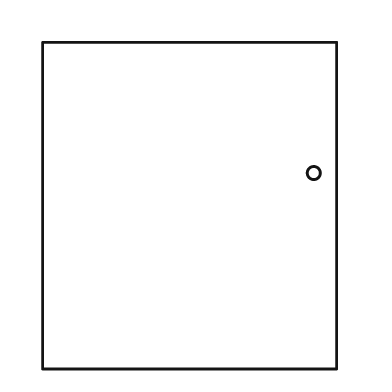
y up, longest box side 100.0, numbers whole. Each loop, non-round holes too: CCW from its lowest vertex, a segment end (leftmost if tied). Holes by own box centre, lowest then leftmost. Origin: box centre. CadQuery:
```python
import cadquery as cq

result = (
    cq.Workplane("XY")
    .moveTo(-45.0, -50.0)
    .lineTo(45.0, -50.0)
    .lineTo(45.0, 50.0)
    .lineTo(-45.0, 50.0)
    .close()
    .moveTo(38.0, 10.0)
    .circle(2.0)
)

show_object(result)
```